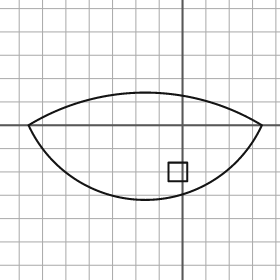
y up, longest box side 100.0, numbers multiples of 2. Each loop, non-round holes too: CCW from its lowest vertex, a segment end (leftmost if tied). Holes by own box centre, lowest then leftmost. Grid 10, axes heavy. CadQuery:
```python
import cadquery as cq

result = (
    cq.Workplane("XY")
    .moveTo(-66.0, 0.0)
    .threePointArc((-16.0, -32.0), (34.0, 0.0))
    .threePointArc((-16.0, 14.0), (-66.0, 0.0))
    .close()
    .moveTo(-6.0, -24.0)
    .lineTo(2.0, -24.0)
    .lineTo(2.0, -16.0)
    .lineTo(-6.0, -16.0)
    .close()
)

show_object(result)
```